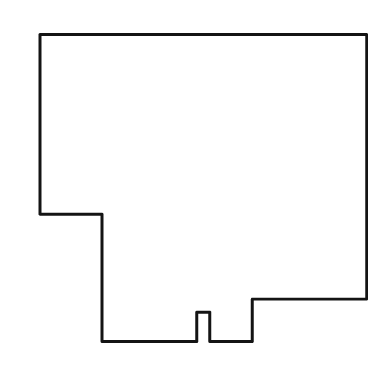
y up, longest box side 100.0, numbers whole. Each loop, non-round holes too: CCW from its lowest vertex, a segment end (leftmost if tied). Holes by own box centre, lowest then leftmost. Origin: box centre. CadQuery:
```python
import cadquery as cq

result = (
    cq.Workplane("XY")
    .moveTo(-31.0, -47.0)
    .lineTo(-2.0, -47.0)
    .lineTo(-2.0, -38.0)
    .lineTo(2.0, -38.0)
    .lineTo(2.0, -47.0)
    .lineTo(15.0, -47.0)
    .lineTo(15.0, -34.0)
    .lineTo(50.0, -34.0)
    .lineTo(50.0, 47.0)
    .lineTo(-50.0, 47.0)
    .lineTo(-50.0, -8.0)
    .lineTo(-31.0, -8.0)
    .close()
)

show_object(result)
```